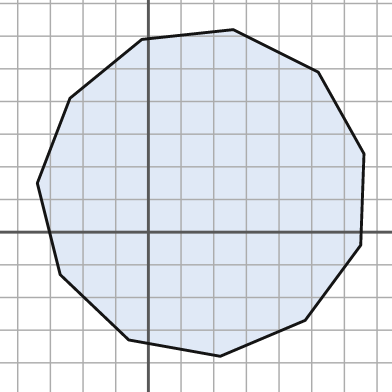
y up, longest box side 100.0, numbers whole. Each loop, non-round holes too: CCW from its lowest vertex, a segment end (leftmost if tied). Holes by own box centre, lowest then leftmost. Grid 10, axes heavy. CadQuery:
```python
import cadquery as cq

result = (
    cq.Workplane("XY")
    .moveTo(22.0, -38.0)
    .lineTo(48.0, -27.0)
    .lineTo(65.0, -4.0)
    .lineTo(66.0, 24.0)
    .lineTo(52.0, 49.0)
    .lineTo(26.0, 62.0)
    .lineTo(-2.0, 59.0)
    .lineTo(-24.0, 41.0)
    .lineTo(-34.0, 15.0)
    .lineTo(-27.0, -13.0)
    .lineTo(-6.0, -33.0)
    .close()
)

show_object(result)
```